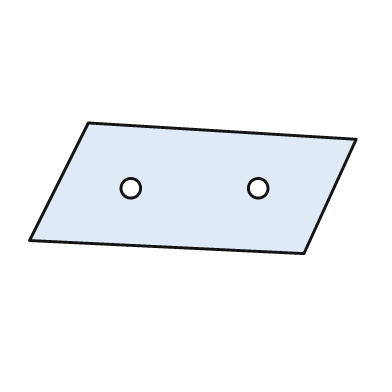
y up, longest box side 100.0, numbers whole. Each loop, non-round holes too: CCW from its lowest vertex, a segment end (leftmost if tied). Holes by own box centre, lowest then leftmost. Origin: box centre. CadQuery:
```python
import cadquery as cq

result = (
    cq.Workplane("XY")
    .moveTo(34.0, -20.0)
    .lineTo(50.0, 15.0)
    .lineTo(-32.0, 20.0)
    .lineTo(-50.0, -16.0)
    .close()
    .moveTo(-19.0, 0.0)
    .circle(3.0)
    .moveTo(20.0, 0.0)
    .circle(3.0)
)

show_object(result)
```